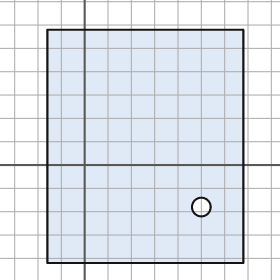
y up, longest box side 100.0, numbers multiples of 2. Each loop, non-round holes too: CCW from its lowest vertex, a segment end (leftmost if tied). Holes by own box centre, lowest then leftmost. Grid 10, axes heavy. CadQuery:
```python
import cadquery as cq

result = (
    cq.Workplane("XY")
    .moveTo(-16.0, -42.0)
    .lineTo(68.0, -42.0)
    .lineTo(68.0, 58.0)
    .lineTo(-16.0, 58.0)
    .close()
    .moveTo(50.0, -18.0)
    .circle(4.0)
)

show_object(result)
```